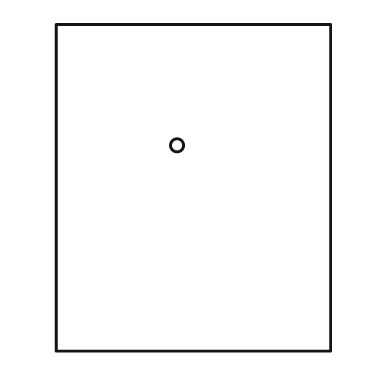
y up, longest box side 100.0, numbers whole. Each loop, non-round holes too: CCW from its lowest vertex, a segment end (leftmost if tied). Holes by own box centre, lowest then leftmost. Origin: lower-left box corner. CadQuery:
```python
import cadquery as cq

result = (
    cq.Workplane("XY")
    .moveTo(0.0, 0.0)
    .lineTo(84.0, 0.0)
    .lineTo(84.0, 100.0)
    .lineTo(0.0, 100.0)
    .close()
    .moveTo(37.0, 63.0)
    .circle(2.0)
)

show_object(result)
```